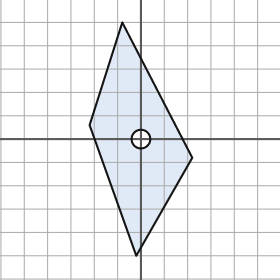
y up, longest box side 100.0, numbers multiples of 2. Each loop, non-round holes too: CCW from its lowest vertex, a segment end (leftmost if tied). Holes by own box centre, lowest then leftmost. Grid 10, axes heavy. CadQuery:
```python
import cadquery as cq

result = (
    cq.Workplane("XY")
    .moveTo(-2.0, -50.0)
    .lineTo(22.0, -8.0)
    .lineTo(-8.0, 50.0)
    .lineTo(-22.0, 6.0)
    .close()
    .moveTo(0.0, 0.0)
    .circle(4.0)
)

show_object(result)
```